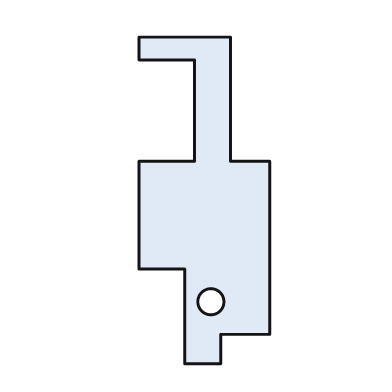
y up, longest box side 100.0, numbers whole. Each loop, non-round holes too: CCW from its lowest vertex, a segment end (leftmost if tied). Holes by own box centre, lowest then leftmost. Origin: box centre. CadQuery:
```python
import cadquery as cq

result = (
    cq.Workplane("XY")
    .moveTo(-6.0, -50.0)
    .lineTo(5.0, -50.0)
    .lineTo(5.0, -41.0)
    .lineTo(20.0, -41.0)
    .lineTo(20.0, 12.0)
    .lineTo(8.0, 12.0)
    .lineTo(8.0, 50.0)
    .lineTo(-20.0, 50.0)
    .lineTo(-20.0, 43.0)
    .lineTo(-3.0, 43.0)
    .lineTo(-3.0, 12.0)
    .lineTo(-20.0, 12.0)
    .lineTo(-20.0, -21.0)
    .lineTo(-6.0, -21.0)
    .close()
    .moveTo(2.0, -31.0)
    .circle(4.0)
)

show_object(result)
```